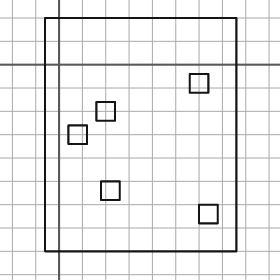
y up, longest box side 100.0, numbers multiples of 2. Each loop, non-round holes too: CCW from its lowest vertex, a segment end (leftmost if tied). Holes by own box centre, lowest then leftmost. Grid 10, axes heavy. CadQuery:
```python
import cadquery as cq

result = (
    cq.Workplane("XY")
    .moveTo(-6.0, -80.0)
    .lineTo(76.0, -80.0)
    .lineTo(76.0, 20.0)
    .lineTo(-6.0, 20.0)
    .close()
    .moveTo(60.0, -68.0)
    .lineTo(68.0, -68.0)
    .lineTo(68.0, -60.0)
    .lineTo(60.0, -60.0)
    .close()
    .moveTo(18.0, -58.0)
    .lineTo(26.0, -58.0)
    .lineTo(26.0, -50.0)
    .lineTo(18.0, -50.0)
    .close()
    .moveTo(4.0, -34.0)
    .lineTo(12.0, -34.0)
    .lineTo(12.0, -26.0)
    .lineTo(4.0, -26.0)
    .close()
    .moveTo(16.0, -24.0)
    .lineTo(24.0, -24.0)
    .lineTo(24.0, -16.0)
    .lineTo(16.0, -16.0)
    .close()
    .moveTo(56.0, -12.0)
    .lineTo(64.0, -12.0)
    .lineTo(64.0, -4.0)
    .lineTo(56.0, -4.0)
    .close()
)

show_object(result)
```